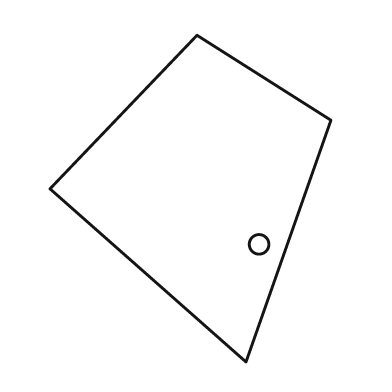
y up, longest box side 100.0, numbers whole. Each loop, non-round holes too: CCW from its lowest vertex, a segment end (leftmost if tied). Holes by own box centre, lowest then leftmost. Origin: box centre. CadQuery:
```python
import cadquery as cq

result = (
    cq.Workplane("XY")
    .moveTo(17.0, -50.0)
    .lineTo(43.0, 24.0)
    .lineTo(2.0, 50.0)
    .lineTo(-43.0, 3.0)
    .close()
    .moveTo(21.0, -14.0)
    .circle(3.0)
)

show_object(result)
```